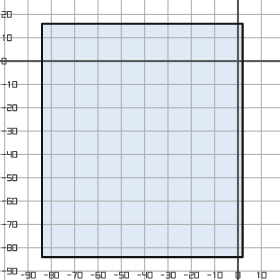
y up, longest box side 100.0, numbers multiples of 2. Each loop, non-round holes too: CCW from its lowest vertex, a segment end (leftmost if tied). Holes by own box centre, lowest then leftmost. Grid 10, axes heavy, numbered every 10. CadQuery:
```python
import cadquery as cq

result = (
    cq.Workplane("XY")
    .moveTo(-84.0, -84.0)
    .lineTo(2.0, -84.0)
    .lineTo(2.0, 16.0)
    .lineTo(-84.0, 16.0)
    .close()
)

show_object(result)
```